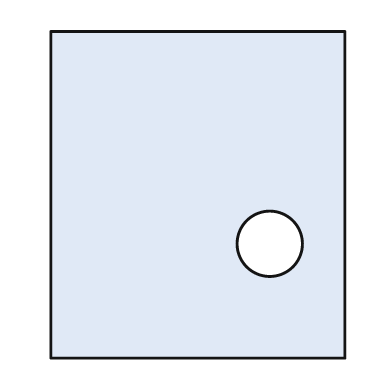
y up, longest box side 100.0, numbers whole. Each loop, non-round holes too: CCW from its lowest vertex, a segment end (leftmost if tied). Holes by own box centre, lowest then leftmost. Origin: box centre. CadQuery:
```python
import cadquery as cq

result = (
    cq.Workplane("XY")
    .moveTo(-45.0, -50.0)
    .lineTo(45.0, -50.0)
    .lineTo(45.0, 50.0)
    .lineTo(-45.0, 50.0)
    .close()
    .moveTo(22.0, -15.0)
    .circle(10.0)
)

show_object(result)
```